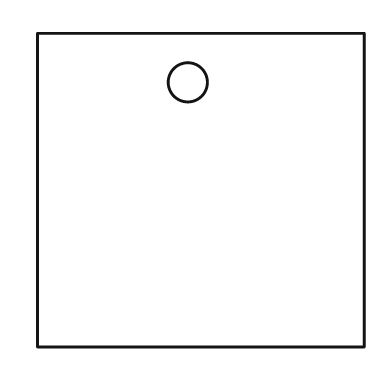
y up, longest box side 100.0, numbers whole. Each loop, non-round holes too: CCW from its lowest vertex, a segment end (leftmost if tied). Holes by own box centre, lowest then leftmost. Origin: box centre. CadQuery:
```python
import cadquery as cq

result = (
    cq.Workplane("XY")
    .moveTo(-50.0, -48.0)
    .lineTo(50.0, -48.0)
    .lineTo(50.0, 48.0)
    .lineTo(-50.0, 48.0)
    .close()
    .moveTo(-4.0, 33.0)
    .circle(6.0)
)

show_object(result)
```